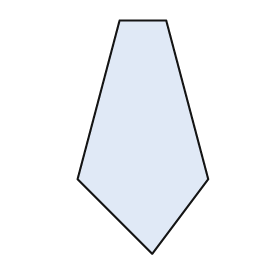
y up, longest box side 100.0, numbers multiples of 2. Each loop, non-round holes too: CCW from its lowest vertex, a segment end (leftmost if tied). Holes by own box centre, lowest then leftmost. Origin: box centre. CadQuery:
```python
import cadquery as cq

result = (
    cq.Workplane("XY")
    .moveTo(4.0, -50.0)
    .lineTo(28.0, -18.0)
    .lineTo(10.0, 50.0)
    .lineTo(-10.0, 50.0)
    .lineTo(-28.0, -18.0)
    .close()
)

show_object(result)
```